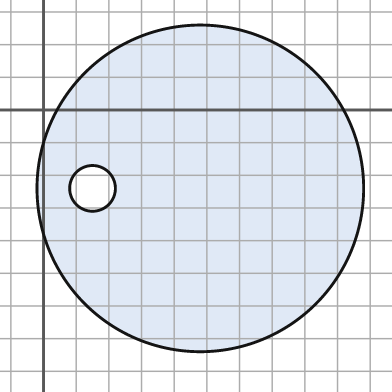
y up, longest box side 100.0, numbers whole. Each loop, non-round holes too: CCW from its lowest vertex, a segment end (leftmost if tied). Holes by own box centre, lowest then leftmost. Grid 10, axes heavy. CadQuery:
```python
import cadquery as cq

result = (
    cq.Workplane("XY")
    .moveTo(48.0, -24.0)
    .circle(50.0)
    .moveTo(15.0, -24.0)
    .circle(7.0)
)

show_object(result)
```